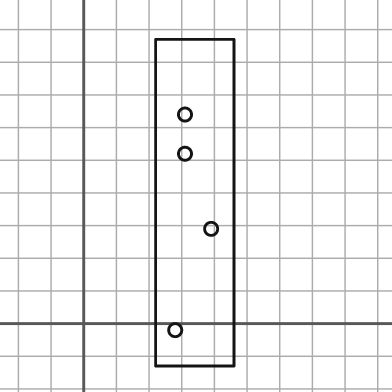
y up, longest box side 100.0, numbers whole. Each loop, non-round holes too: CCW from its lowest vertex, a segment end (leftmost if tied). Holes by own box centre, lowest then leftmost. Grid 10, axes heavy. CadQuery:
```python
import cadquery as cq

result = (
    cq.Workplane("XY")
    .moveTo(22.0, -13.0)
    .lineTo(46.0, -13.0)
    .lineTo(46.0, 87.0)
    .lineTo(22.0, 87.0)
    .close()
    .moveTo(28.0, -2.0)
    .circle(2.0)
    .moveTo(39.0, 29.0)
    .circle(2.0)
    .moveTo(31.0, 52.0)
    .circle(2.0)
    .moveTo(31.0, 64.0)
    .circle(2.0)
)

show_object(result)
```